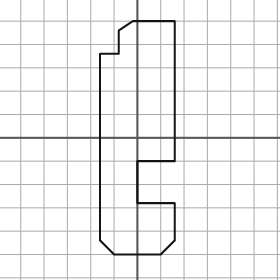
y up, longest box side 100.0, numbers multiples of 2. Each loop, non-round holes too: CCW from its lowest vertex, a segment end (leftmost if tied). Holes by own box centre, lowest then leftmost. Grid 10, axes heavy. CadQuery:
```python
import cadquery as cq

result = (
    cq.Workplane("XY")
    .moveTo(-10.0, -50.0)
    .lineTo(10.0, -50.0)
    .lineTo(16.0, -44.0)
    .lineTo(16.0, -28.0)
    .lineTo(0.0, -28.0)
    .lineTo(0.0, -10.0)
    .lineTo(16.0, -10.0)
    .lineTo(16.0, 50.0)
    .lineTo(-2.0, 50.0)
    .lineTo(-8.0, 46.0)
    .lineTo(-8.0, 36.0)
    .lineTo(-16.0, 36.0)
    .lineTo(-16.0, -44.0)
    .close()
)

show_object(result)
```